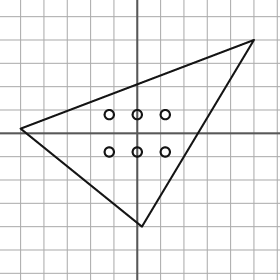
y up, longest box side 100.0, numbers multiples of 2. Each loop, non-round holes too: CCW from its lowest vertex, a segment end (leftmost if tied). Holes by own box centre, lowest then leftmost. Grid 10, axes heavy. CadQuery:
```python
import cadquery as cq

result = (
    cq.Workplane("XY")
    .moveTo(2.0, -40.0)
    .lineTo(50.0, 40.0)
    .lineTo(-50.0, 2.0)
    .close()
    .moveTo(-12.0, -8.0)
    .circle(2.0)
    .moveTo(0.0, -8.0)
    .circle(2.0)
    .moveTo(12.0, -8.0)
    .circle(2.0)
    .moveTo(-12.0, 8.0)
    .circle(2.0)
    .moveTo(0.0, 8.0)
    .circle(2.0)
    .moveTo(12.0, 8.0)
    .circle(2.0)
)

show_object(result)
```